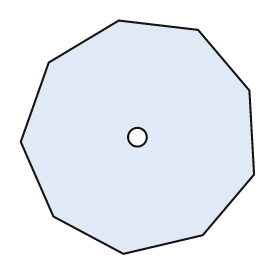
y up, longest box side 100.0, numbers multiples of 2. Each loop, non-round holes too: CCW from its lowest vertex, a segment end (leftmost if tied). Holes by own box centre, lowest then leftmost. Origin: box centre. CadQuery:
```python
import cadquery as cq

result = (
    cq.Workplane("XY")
    .moveTo(-6.0, -50.0)
    .lineTo(28.0, -42.0)
    .lineTo(50.0, -16.0)
    .lineTo(48.0, 20.0)
    .lineTo(26.0, 46.0)
    .lineTo(-8.0, 50.0)
    .lineTo(-38.0, 32.0)
    .lineTo(-50.0, -2.0)
    .lineTo(-36.0, -34.0)
    .close()
    .moveTo(0.0, 0.0)
    .circle(4.0)
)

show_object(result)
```